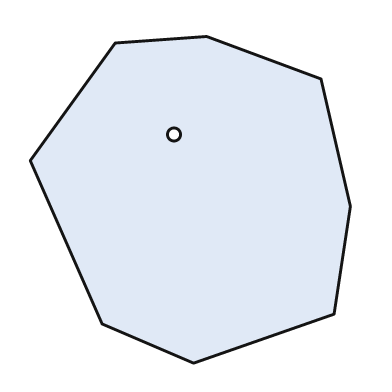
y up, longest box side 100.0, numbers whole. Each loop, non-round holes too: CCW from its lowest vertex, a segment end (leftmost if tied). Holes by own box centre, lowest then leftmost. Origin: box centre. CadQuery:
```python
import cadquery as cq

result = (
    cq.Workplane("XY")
    .moveTo(1.0, -50.0)
    .lineTo(44.0, -35.0)
    .lineTo(49.0, -2.0)
    .lineTo(40.0, 37.0)
    .lineTo(5.0, 50.0)
    .lineTo(-23.0, 48.0)
    .lineTo(-49.0, 12.0)
    .lineTo(-27.0, -38.0)
    .close()
    .moveTo(-5.0, 20.0)
    .circle(2.0)
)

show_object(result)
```